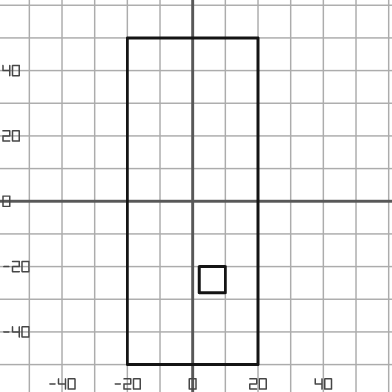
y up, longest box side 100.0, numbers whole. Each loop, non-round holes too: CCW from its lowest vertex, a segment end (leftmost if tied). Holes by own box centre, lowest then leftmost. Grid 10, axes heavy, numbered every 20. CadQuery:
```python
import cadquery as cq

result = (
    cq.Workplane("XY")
    .moveTo(-20.0, -50.0)
    .lineTo(20.0, -50.0)
    .lineTo(20.0, 50.0)
    .lineTo(-20.0, 50.0)
    .close()
    .moveTo(2.0, -28.0)
    .lineTo(10.0, -28.0)
    .lineTo(10.0, -20.0)
    .lineTo(2.0, -20.0)
    .close()
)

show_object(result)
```